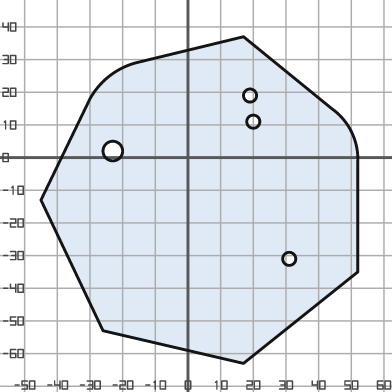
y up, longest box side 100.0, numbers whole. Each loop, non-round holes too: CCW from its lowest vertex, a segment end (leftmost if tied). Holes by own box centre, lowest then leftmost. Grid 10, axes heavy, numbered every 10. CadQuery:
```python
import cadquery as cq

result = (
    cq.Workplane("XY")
    .moveTo(17.0, -63.0)
    .lineTo(52.0, -35.0)
    .lineTo(52.0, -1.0)
    .threePointArc((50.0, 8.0), (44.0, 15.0))
    .lineTo(17.0, 37.0)
    .lineTo(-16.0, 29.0)
    .threePointArc((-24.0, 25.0), (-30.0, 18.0))
    .lineTo(-45.0, -13.0)
    .lineTo(-26.0, -53.0)
    .close()
    .moveTo(31.0, -31.0)
    .circle(2.0)
    .moveTo(-23.0, 2.0)
    .circle(3.0)
    .moveTo(20.0, 11.0)
    .circle(2.0)
    .moveTo(19.0, 19.0)
    .circle(2.0)
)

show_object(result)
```